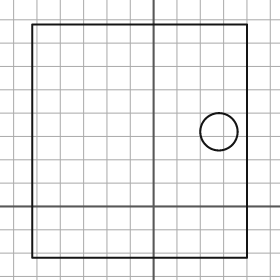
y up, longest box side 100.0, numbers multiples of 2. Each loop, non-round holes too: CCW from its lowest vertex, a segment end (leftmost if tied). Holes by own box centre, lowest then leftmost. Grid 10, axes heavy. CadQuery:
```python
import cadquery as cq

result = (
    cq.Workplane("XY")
    .moveTo(-52.0, -22.0)
    .lineTo(40.0, -22.0)
    .lineTo(40.0, 78.0)
    .lineTo(-52.0, 78.0)
    .close()
    .moveTo(28.0, 32.0)
    .circle(8.0)
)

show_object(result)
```